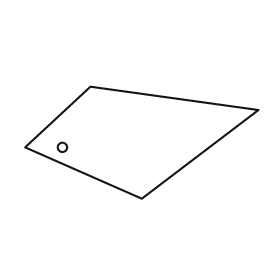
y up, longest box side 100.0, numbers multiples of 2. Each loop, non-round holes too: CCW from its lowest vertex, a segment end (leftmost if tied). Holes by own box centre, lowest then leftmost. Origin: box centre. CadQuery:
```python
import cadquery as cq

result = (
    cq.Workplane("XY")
    .moveTo(0.0, -24.0)
    .lineTo(50.0, 14.0)
    .lineTo(-22.0, 24.0)
    .lineTo(-50.0, -2.0)
    .close()
    .moveTo(-34.0, -2.0)
    .circle(2.0)
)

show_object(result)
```